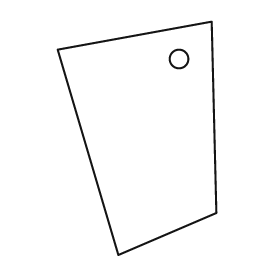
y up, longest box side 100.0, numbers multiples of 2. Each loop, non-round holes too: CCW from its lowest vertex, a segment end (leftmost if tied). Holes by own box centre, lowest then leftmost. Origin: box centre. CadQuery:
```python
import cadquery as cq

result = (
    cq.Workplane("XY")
    .moveTo(-8.0, -50.0)
    .lineTo(34.0, -32.0)
    .lineTo(32.0, 50.0)
    .lineTo(-34.0, 38.0)
    .close()
    .moveTo(18.0, 34.0)
    .circle(4.0)
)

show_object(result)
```